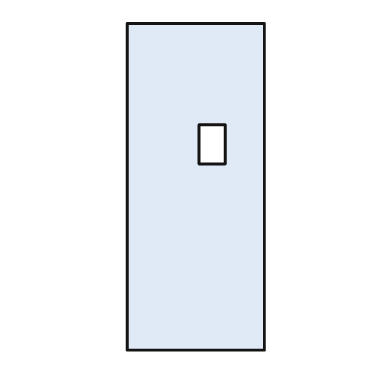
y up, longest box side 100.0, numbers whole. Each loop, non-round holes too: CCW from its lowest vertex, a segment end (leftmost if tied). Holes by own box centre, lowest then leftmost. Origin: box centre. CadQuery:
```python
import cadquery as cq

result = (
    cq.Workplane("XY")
    .moveTo(-21.0, -50.0)
    .lineTo(21.0, -50.0)
    .lineTo(21.0, 50.0)
    .lineTo(-21.0, 50.0)
    .close()
    .moveTo(1.0, 7.0)
    .lineTo(9.0, 7.0)
    .lineTo(9.0, 19.0)
    .lineTo(1.0, 19.0)
    .close()
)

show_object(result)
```